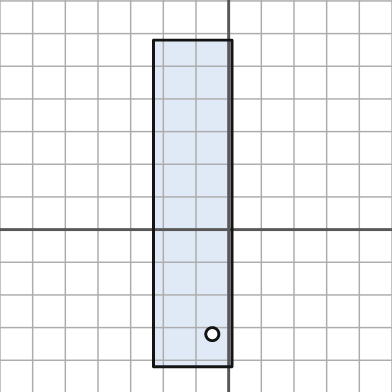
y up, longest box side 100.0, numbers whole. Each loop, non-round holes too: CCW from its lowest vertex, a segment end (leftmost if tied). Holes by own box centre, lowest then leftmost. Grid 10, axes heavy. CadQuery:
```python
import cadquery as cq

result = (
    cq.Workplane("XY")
    .moveTo(-23.0, -42.0)
    .lineTo(1.0, -42.0)
    .lineTo(1.0, 58.0)
    .lineTo(-23.0, 58.0)
    .close()
    .moveTo(-5.0, -32.0)
    .circle(2.0)
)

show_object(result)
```